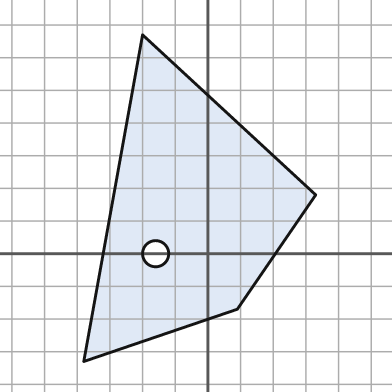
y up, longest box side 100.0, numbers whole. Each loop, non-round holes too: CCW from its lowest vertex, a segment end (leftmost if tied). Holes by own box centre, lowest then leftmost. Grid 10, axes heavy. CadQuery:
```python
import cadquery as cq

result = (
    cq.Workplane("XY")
    .moveTo(-38.0, -33.0)
    .lineTo(9.0, -17.0)
    .lineTo(33.0, 18.0)
    .lineTo(-20.0, 67.0)
    .close()
    .moveTo(-16.0, 0.0)
    .circle(4.0)
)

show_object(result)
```